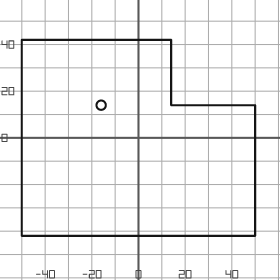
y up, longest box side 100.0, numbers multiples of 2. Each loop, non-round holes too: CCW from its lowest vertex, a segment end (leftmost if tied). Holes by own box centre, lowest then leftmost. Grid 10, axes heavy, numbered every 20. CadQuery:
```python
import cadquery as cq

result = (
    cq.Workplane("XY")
    .moveTo(-50.0, -42.0)
    .lineTo(50.0, -42.0)
    .lineTo(50.0, 14.0)
    .lineTo(14.0, 14.0)
    .lineTo(14.0, 42.0)
    .lineTo(-50.0, 42.0)
    .close()
    .moveTo(-16.0, 14.0)
    .circle(2.0)
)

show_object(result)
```